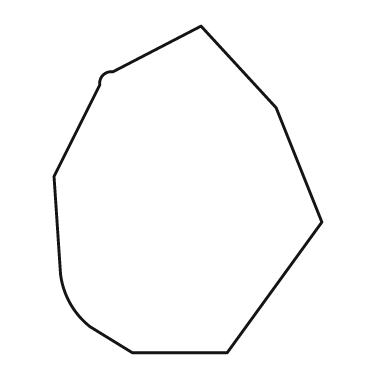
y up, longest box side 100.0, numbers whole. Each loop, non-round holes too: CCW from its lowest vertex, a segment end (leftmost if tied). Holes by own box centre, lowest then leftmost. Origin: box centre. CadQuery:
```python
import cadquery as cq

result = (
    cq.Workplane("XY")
    .moveTo(-17.0, -50.0)
    .lineTo(12.0, -50.0)
    .lineTo(41.0, -10.0)
    .lineTo(27.0, 25.0)
    .lineTo(4.0, 50.0)
    .lineTo(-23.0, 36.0)
    .threePointArc((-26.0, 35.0), (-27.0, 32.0))
    .lineTo(-41.0, 4.0)
    .lineTo(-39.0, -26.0)
    .threePointArc((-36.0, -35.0), (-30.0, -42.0))
    .close()
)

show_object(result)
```